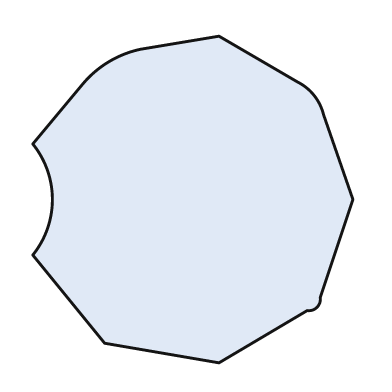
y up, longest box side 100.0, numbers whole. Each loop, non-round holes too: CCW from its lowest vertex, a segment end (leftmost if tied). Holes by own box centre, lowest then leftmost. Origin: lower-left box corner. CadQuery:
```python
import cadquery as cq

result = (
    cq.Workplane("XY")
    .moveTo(57.0, 0.0)
    .lineTo(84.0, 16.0)
    .threePointArc((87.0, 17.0), (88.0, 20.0))
    .lineTo(98.0, 50.0)
    .lineTo(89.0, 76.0)
    .threePointArc((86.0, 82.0), (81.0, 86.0))
    .lineTo(57.0, 100.0)
    .lineTo(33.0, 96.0)
    .threePointArc((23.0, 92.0), (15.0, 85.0))
    .lineTo(0.0, 67.0)
    .threePointArc((6.0, 50.0), (0.0, 33.0))
    .lineTo(22.0, 6.0)
    .close()
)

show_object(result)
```